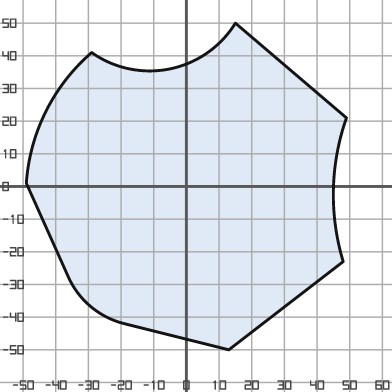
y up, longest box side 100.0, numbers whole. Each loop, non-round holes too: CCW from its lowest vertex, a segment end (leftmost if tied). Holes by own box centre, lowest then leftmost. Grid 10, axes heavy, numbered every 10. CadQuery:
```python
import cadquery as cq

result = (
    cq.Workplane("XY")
    .moveTo(13.0, -50.0)
    .lineTo(48.0, -23.0)
    .threePointArc((45.0, -1.0), (49.0, 21.0))
    .lineTo(15.0, 50.0)
    .threePointArc((-5.0, 36.0), (-29.0, 41.0))
    .threePointArc((-43.0, 23.0), (-49.0, 1.0))
    .lineTo(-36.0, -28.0)
    .threePointArc((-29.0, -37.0), (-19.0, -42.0))
    .close()
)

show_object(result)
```